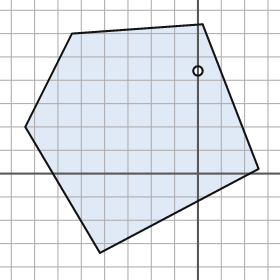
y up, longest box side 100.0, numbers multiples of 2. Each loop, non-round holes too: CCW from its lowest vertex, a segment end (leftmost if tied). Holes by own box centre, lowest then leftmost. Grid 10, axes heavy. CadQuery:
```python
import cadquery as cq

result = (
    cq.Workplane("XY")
    .moveTo(-42.0, -34.0)
    .lineTo(26.0, 2.0)
    .lineTo(2.0, 64.0)
    .lineTo(-54.0, 60.0)
    .lineTo(-74.0, 20.0)
    .close()
    .moveTo(0.0, 44.0)
    .circle(2.0)
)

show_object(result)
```